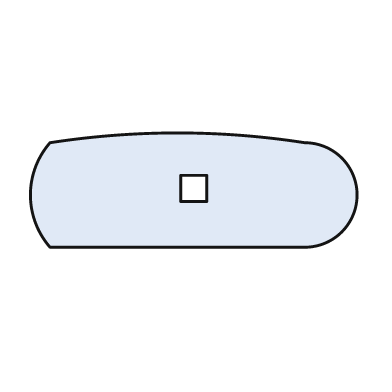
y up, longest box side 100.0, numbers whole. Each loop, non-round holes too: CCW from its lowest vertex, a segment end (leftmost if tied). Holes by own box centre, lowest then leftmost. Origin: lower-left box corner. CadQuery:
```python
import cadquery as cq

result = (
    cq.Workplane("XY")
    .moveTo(6.0, 0.0)
    .lineTo(84.0, 0.0)
    .threePointArc((100.0, 16.0), (84.0, 32.0))
    .threePointArc((45.0, 35.0), (6.0, 32.0))
    .threePointArc((0.0, 16.0), (6.0, 0.0))
    .close()
    .moveTo(46.0, 14.0)
    .lineTo(54.0, 14.0)
    .lineTo(54.0, 22.0)
    .lineTo(46.0, 22.0)
    .close()
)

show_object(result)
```